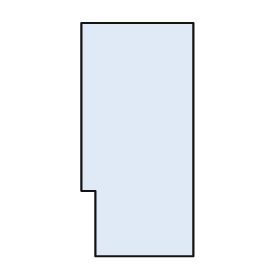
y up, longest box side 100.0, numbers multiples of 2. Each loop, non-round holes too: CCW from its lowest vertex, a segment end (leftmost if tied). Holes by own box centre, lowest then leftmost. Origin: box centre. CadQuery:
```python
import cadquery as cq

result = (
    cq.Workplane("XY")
    .moveTo(-18.0, -50.0)
    .lineTo(24.0, -50.0)
    .lineTo(24.0, 50.0)
    .lineTo(-24.0, 50.0)
    .lineTo(-24.0, -22.0)
    .lineTo(-18.0, -22.0)
    .close()
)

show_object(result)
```